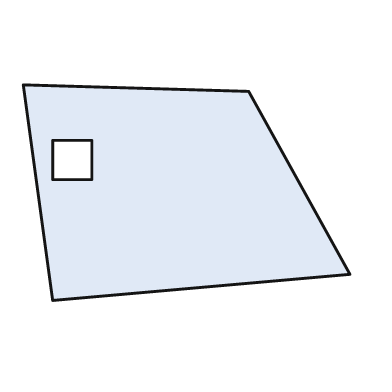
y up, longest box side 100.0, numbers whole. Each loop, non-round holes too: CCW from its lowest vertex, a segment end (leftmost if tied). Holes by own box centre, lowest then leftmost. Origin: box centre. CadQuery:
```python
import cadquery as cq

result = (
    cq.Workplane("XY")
    .moveTo(-41.0, -33.0)
    .lineTo(50.0, -25.0)
    .lineTo(19.0, 31.0)
    .lineTo(-50.0, 33.0)
    .close()
    .moveTo(-41.0, 4.0)
    .lineTo(-29.0, 4.0)
    .lineTo(-29.0, 16.0)
    .lineTo(-41.0, 16.0)
    .close()
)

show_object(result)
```